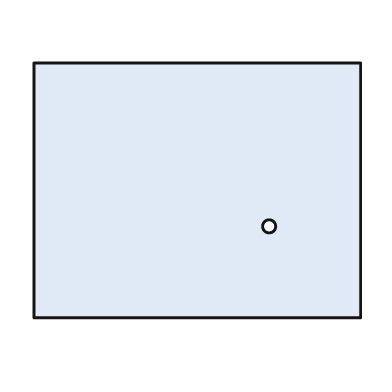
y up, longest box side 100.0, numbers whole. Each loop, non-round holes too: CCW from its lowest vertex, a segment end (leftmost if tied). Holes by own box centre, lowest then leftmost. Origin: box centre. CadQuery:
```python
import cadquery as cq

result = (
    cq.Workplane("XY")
    .moveTo(-50.0, -39.0)
    .lineTo(50.0, -39.0)
    .lineTo(50.0, 39.0)
    .lineTo(-50.0, 39.0)
    .close()
    .moveTo(22.0, -11.0)
    .circle(2.0)
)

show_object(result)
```